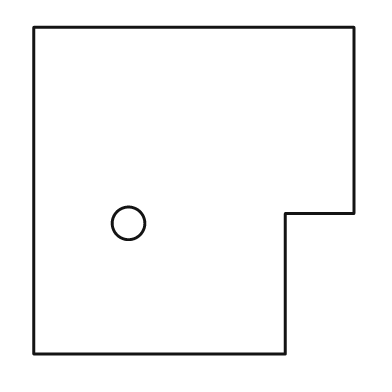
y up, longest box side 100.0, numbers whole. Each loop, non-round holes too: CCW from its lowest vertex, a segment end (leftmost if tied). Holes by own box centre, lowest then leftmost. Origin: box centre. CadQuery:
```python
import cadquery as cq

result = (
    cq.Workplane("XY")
    .moveTo(-49.0, -50.0)
    .lineTo(28.0, -50.0)
    .lineTo(28.0, -7.0)
    .lineTo(49.0, -7.0)
    .lineTo(49.0, 50.0)
    .lineTo(-49.0, 50.0)
    .close()
    .moveTo(-20.0, -10.0)
    .circle(5.0)
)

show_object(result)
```